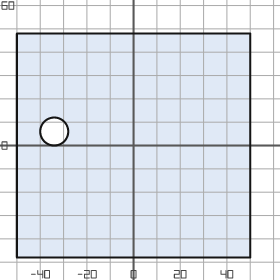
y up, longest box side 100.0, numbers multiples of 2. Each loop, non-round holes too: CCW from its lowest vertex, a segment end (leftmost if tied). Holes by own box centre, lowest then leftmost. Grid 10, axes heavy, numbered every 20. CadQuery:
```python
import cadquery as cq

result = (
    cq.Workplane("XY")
    .moveTo(-50.0, -48.0)
    .lineTo(50.0, -48.0)
    .lineTo(50.0, 48.0)
    .lineTo(-50.0, 48.0)
    .close()
    .moveTo(-34.0, 6.0)
    .circle(6.0)
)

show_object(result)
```